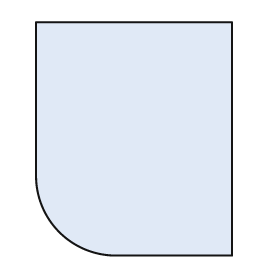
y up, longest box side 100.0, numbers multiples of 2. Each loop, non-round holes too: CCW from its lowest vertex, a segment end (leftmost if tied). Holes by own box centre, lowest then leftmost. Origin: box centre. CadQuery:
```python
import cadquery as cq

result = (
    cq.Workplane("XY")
    .moveTo(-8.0, -50.0)
    .lineTo(42.0, -50.0)
    .lineTo(42.0, 50.0)
    .lineTo(-42.0, 50.0)
    .lineTo(-42.0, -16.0)
    .threePointArc((-32.0, -40.0), (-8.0, -50.0))
    .close()
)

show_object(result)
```